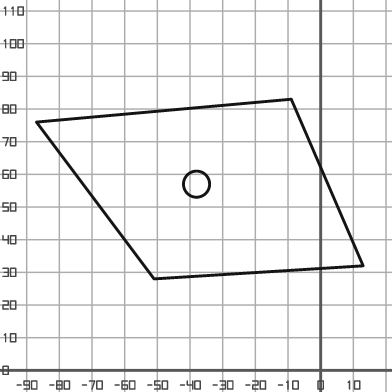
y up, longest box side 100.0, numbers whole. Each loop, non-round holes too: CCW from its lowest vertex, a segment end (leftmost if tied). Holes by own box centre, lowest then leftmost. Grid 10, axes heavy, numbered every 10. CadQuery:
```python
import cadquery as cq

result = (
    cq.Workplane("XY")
    .moveTo(-51.0, 28.0)
    .lineTo(13.0, 32.0)
    .lineTo(-9.0, 83.0)
    .lineTo(-87.0, 76.0)
    .close()
    .moveTo(-38.0, 57.0)
    .circle(4.0)
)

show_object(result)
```